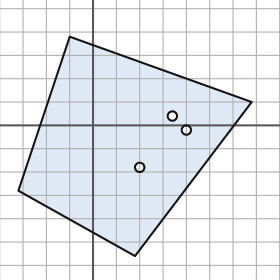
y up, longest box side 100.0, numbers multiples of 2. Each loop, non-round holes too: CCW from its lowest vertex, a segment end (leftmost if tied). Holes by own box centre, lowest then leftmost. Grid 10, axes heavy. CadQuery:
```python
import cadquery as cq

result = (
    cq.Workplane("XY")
    .moveTo(18.0, -56.0)
    .lineTo(68.0, 10.0)
    .lineTo(-10.0, 38.0)
    .lineTo(-32.0, -28.0)
    .close()
    .moveTo(20.0, -18.0)
    .circle(2.0)
    .moveTo(40.0, -2.0)
    .circle(2.0)
    .moveTo(34.0, 4.0)
    .circle(2.0)
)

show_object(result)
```